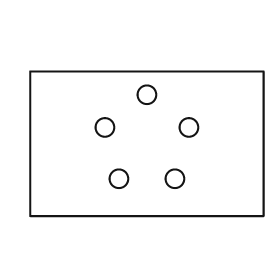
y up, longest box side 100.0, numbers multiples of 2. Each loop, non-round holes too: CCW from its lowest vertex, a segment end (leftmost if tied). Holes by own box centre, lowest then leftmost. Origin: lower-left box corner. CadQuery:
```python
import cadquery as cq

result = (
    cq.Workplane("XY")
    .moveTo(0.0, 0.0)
    .lineTo(100.0, 0.0)
    .lineTo(100.0, 62.0)
    .lineTo(0.0, 62.0)
    .close()
    .moveTo(38.0, 16.0)
    .circle(4.0)
    .moveTo(62.0, 16.0)
    .circle(4.0)
    .moveTo(32.0, 38.0)
    .circle(4.0)
    .moveTo(68.0, 38.0)
    .circle(4.0)
    .moveTo(50.0, 52.0)
    .circle(4.0)
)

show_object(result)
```